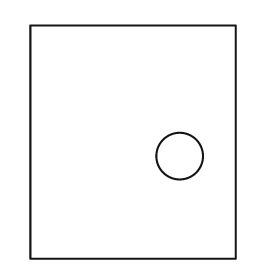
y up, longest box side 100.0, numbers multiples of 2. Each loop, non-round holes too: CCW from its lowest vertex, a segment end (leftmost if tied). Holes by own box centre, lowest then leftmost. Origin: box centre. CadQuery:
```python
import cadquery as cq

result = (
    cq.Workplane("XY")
    .moveTo(-44.0, -50.0)
    .lineTo(44.0, -50.0)
    .lineTo(44.0, 50.0)
    .lineTo(-44.0, 50.0)
    .close()
    .moveTo(20.0, -6.0)
    .circle(10.0)
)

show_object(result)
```